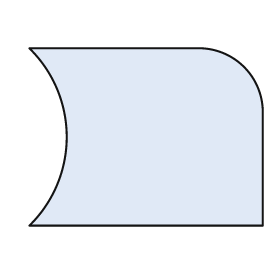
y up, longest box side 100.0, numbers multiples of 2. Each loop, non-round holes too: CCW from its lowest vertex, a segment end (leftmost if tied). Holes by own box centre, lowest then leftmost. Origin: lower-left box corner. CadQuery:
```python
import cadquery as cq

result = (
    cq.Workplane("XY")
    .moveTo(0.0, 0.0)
    .lineTo(100.0, 0.0)
    .lineTo(100.0, 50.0)
    .threePointArc((92.0, 68.0), (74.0, 76.0))
    .lineTo(0.0, 76.0)
    .threePointArc((16.0, 38.0), (0.0, 0.0))
    .close()
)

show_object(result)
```